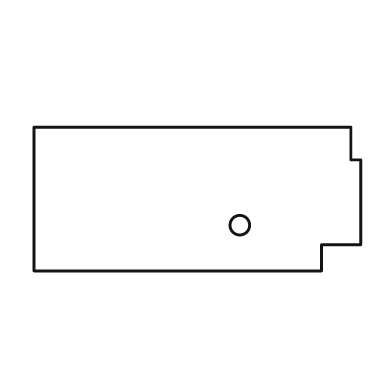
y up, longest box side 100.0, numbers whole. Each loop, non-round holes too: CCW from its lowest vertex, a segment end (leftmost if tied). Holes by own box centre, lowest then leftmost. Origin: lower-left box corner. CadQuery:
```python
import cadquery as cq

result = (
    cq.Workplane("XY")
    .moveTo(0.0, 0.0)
    .lineTo(88.0, 0.0)
    .lineTo(88.0, 8.0)
    .lineTo(100.0, 8.0)
    .lineTo(100.0, 34.0)
    .lineTo(97.0, 34.0)
    .lineTo(97.0, 44.0)
    .lineTo(0.0, 44.0)
    .close()
    .moveTo(63.0, 14.0)
    .circle(3.0)
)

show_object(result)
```